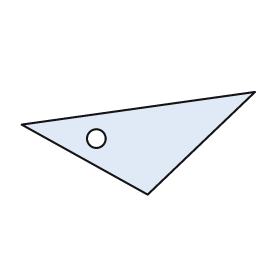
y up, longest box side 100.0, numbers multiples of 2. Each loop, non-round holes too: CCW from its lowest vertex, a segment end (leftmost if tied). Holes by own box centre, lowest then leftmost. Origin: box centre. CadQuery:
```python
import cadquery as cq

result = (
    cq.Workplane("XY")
    .moveTo(4.0, -22.0)
    .lineTo(50.0, 22.0)
    .lineTo(-50.0, 8.0)
    .close()
    .moveTo(-18.0, 2.0)
    .circle(4.0)
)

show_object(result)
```